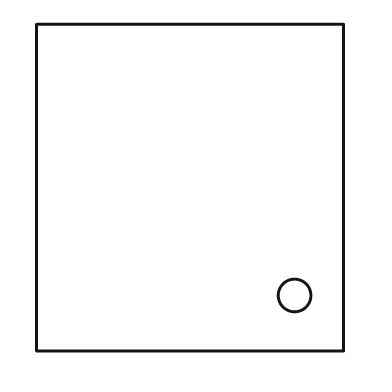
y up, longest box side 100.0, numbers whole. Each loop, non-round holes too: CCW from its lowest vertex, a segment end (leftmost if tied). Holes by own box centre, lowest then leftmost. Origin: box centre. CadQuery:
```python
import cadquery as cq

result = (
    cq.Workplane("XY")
    .moveTo(-47.0, -50.0)
    .lineTo(47.0, -50.0)
    .lineTo(47.0, 50.0)
    .lineTo(-47.0, 50.0)
    .close()
    .moveTo(32.0, -33.0)
    .circle(5.0)
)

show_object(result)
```